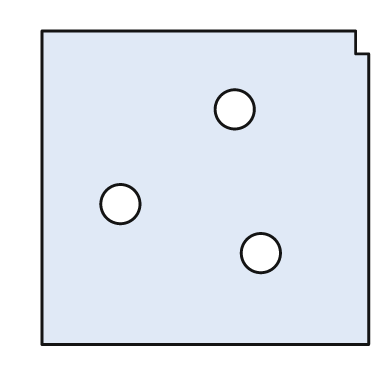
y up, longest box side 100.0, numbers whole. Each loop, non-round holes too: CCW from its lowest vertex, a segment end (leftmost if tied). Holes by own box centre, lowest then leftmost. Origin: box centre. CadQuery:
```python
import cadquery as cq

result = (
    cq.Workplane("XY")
    .moveTo(-50.0, -48.0)
    .lineTo(50.0, -48.0)
    .lineTo(50.0, 41.0)
    .lineTo(46.0, 41.0)
    .lineTo(46.0, 48.0)
    .lineTo(-50.0, 48.0)
    .close()
    .moveTo(17.0, -20.0)
    .circle(6.0)
    .moveTo(-26.0, -5.0)
    .circle(6.0)
    .moveTo(9.0, 24.0)
    .circle(6.0)
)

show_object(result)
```